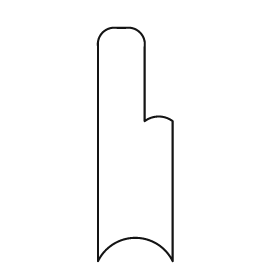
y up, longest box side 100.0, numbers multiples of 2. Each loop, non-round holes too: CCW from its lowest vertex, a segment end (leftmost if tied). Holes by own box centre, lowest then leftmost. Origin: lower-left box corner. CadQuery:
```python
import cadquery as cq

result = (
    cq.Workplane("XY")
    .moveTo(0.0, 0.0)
    .threePointArc((16.0, 10.0), (32.0, 0.0))
    .lineTo(32.0, 60.0)
    .threePointArc((26.0, 62.0), (20.0, 60.0))
    .lineTo(20.0, 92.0)
    .threePointArc((18.0, 98.0), (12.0, 100.0))
    .lineTo(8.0, 100.0)
    .threePointArc((2.0, 98.0), (0.0, 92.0))
    .close()
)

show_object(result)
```